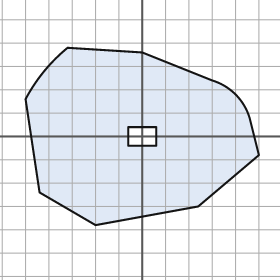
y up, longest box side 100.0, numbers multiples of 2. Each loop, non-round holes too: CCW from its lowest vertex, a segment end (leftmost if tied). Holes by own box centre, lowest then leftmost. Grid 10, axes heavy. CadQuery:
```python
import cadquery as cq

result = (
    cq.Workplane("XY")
    .moveTo(-20.0, -38.0)
    .lineTo(24.0, -30.0)
    .lineTo(50.0, -8.0)
    .lineTo(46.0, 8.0)
    .threePointArc((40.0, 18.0), (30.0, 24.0))
    .lineTo(0.0, 36.0)
    .lineTo(-32.0, 38.0)
    .threePointArc((-42.0, 28.0), (-50.0, 16.0))
    .lineTo(-44.0, -24.0)
    .close()
    .moveTo(-6.0, -4.0)
    .lineTo(6.0, -4.0)
    .lineTo(6.0, 4.0)
    .lineTo(-6.0, 4.0)
    .close()
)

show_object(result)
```